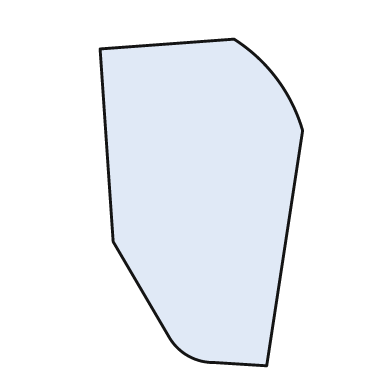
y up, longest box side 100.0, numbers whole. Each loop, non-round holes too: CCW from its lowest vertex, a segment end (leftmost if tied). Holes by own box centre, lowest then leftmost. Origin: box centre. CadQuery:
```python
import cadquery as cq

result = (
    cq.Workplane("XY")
    .moveTo(20.0, -50.0)
    .lineTo(31.0, 22.0)
    .threePointArc((23.0, 38.0), (10.0, 50.0))
    .lineTo(-31.0, 47.0)
    .lineTo(-27.0, -12.0)
    .lineTo(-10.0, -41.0)
    .threePointArc((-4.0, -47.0), (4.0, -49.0))
    .close()
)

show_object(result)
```